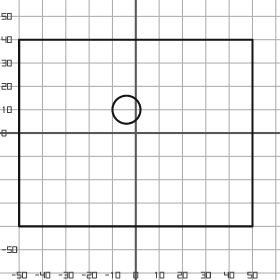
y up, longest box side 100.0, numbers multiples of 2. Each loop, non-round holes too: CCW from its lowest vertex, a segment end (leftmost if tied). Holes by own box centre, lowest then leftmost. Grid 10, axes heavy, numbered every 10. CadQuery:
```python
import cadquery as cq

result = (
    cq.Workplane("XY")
    .moveTo(-50.0, -40.0)
    .lineTo(50.0, -40.0)
    .lineTo(50.0, 40.0)
    .lineTo(-50.0, 40.0)
    .close()
    .moveTo(-4.0, 10.0)
    .circle(6.0)
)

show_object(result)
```